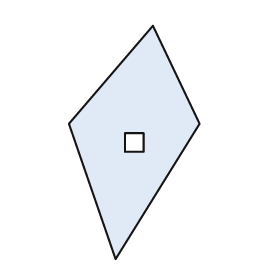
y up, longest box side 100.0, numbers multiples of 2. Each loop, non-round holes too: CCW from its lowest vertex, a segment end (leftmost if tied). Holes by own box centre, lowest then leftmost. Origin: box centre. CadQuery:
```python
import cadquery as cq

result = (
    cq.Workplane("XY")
    .moveTo(-8.0, -50.0)
    .lineTo(28.0, 8.0)
    .lineTo(8.0, 50.0)
    .lineTo(-28.0, 8.0)
    .close()
    .moveTo(-4.0, -4.0)
    .lineTo(4.0, -4.0)
    .lineTo(4.0, 4.0)
    .lineTo(-4.0, 4.0)
    .close()
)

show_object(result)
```